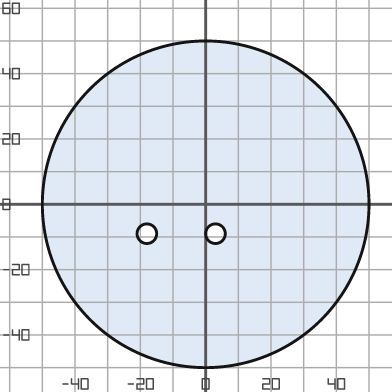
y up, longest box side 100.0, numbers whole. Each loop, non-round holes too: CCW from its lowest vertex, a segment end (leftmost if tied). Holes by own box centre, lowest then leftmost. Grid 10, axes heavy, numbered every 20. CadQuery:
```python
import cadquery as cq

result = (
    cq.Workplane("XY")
    .moveTo(0.0, 0.0)
    .circle(50.0)
    .moveTo(-18.0, -9.0)
    .circle(3.0)
    .moveTo(3.0, -9.0)
    .circle(3.0)
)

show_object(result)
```